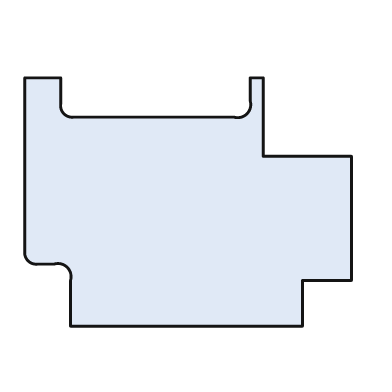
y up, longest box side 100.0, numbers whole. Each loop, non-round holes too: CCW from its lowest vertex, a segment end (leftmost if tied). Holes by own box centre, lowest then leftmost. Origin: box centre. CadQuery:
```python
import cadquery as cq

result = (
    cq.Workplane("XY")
    .moveTo(-36.0, -38.0)
    .lineTo(35.0, -38.0)
    .lineTo(35.0, -24.0)
    .lineTo(50.0, -24.0)
    .lineTo(50.0, 14.0)
    .lineTo(23.0, 14.0)
    .lineTo(23.0, 38.0)
    .lineTo(19.0, 38.0)
    .lineTo(19.0, 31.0)
    .threePointArc((18.0, 27.0), (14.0, 26.0))
    .lineTo(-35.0, 26.0)
    .threePointArc((-38.0, 27.0), (-39.0, 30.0))
    .lineTo(-39.0, 38.0)
    .lineTo(-50.0, 38.0)
    .lineTo(-50.0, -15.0)
    .threePointArc((-49.0, -18.0), (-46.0, -19.0))
    .lineTo(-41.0, -19.0)
    .threePointArc((-37.0, -20.0), (-36.0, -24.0))
    .close()
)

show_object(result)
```